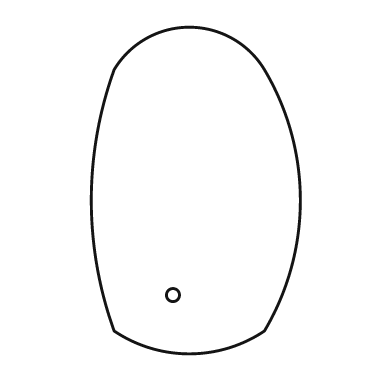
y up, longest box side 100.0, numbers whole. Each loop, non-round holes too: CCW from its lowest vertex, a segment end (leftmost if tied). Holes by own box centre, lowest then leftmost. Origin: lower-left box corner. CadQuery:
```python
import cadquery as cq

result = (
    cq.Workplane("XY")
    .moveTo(7.0, 7.0)
    .threePointArc((30.0, 0.0), (53.0, 7.0))
    .threePointArc((64.0, 47.0), (53.0, 87.0))
    .threePointArc((30.0, 100.0), (7.0, 87.0))
    .threePointArc((0.0, 47.0), (7.0, 7.0))
    .close()
    .moveTo(25.0, 18.0)
    .circle(2.0)
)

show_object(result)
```